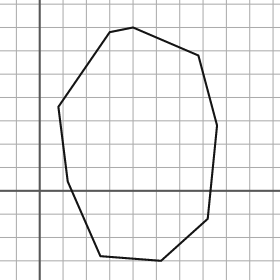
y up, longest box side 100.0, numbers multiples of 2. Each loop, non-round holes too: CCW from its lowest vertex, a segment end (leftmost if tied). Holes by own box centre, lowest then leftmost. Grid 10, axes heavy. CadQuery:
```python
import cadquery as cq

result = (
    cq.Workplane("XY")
    .moveTo(52.0, -30.0)
    .lineTo(72.0, -12.0)
    .lineTo(76.0, 28.0)
    .lineTo(68.0, 58.0)
    .lineTo(40.0, 70.0)
    .lineTo(30.0, 68.0)
    .lineTo(8.0, 36.0)
    .lineTo(12.0, 4.0)
    .lineTo(26.0, -28.0)
    .close()
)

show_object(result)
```